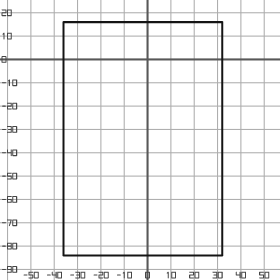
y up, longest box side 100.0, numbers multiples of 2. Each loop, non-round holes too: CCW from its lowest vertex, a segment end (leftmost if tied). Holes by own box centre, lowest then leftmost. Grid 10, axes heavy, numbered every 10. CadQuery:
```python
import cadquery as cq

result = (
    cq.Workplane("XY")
    .moveTo(-36.0, -84.0)
    .lineTo(32.0, -84.0)
    .lineTo(32.0, 16.0)
    .lineTo(-36.0, 16.0)
    .close()
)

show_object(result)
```